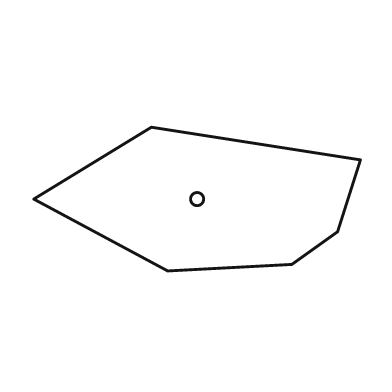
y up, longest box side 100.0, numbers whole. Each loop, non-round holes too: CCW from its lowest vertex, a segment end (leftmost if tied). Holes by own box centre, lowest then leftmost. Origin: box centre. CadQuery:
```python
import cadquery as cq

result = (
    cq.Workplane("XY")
    .moveTo(-9.0, -22.0)
    .lineTo(29.0, -20.0)
    .lineTo(43.0, -10.0)
    .lineTo(50.0, 12.0)
    .lineTo(-14.0, 22.0)
    .lineTo(-50.0, 0.0)
    .close()
    .moveTo(0.0, 0.0)
    .circle(2.0)
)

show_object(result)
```